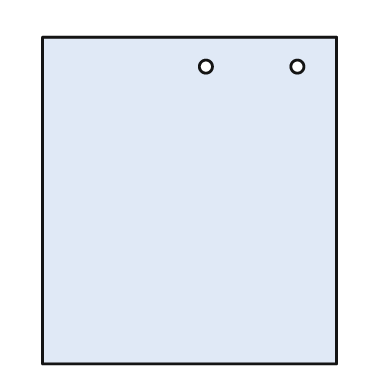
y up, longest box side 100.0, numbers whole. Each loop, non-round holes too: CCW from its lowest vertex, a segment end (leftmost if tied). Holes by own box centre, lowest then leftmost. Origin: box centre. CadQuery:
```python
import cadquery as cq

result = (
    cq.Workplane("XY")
    .moveTo(-45.0, -50.0)
    .lineTo(45.0, -50.0)
    .lineTo(45.0, 50.0)
    .lineTo(-45.0, 50.0)
    .close()
    .moveTo(5.0, 41.0)
    .circle(2.0)
    .moveTo(33.0, 41.0)
    .circle(2.0)
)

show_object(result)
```